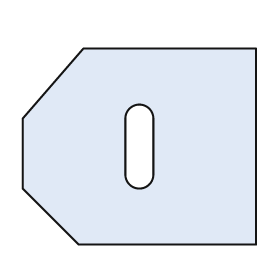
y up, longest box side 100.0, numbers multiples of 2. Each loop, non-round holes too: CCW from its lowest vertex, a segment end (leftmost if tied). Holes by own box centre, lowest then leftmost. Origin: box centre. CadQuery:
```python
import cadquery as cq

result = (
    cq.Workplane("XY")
    .moveTo(-26.0, -42.0)
    .lineTo(50.0, -42.0)
    .lineTo(50.0, 42.0)
    .lineTo(-24.0, 42.0)
    .lineTo(-50.0, 12.0)
    .lineTo(-50.0, -18.0)
    .close()
    .moveTo(-6.0, -12.0)
    .threePointArc((0.0, -18.0), (6.0, -12.0))
    .lineTo(6.0, 12.0)
    .threePointArc((0.0, 18.0), (-6.0, 12.0))
    .close()
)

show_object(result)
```